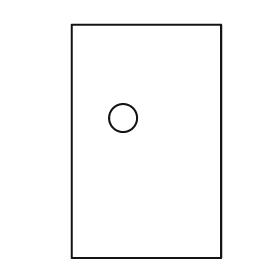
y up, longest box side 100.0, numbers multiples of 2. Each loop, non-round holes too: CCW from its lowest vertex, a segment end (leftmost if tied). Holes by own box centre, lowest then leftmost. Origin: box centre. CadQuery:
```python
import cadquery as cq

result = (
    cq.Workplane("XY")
    .moveTo(-32.0, -50.0)
    .lineTo(32.0, -50.0)
    .lineTo(32.0, 50.0)
    .lineTo(-32.0, 50.0)
    .close()
    .moveTo(-10.0, 10.0)
    .circle(6.0)
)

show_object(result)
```